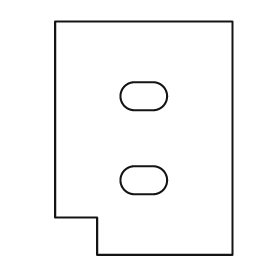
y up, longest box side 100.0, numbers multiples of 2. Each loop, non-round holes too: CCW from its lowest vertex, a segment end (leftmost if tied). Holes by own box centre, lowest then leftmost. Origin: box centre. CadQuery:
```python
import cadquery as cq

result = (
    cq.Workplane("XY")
    .moveTo(-20.0, -50.0)
    .lineTo(38.0, -50.0)
    .lineTo(38.0, 50.0)
    .lineTo(-38.0, 50.0)
    .lineTo(-38.0, -34.0)
    .lineTo(-20.0, -34.0)
    .close()
    .moveTo(-4.0, -24.0)
    .lineTo(4.0, -24.0)
    .threePointArc((10.0, -18.0), (4.0, -12.0))
    .lineTo(-4.0, -12.0)
    .threePointArc((-10.0, -18.0), (-4.0, -24.0))
    .close()
    .moveTo(-4.0, 12.0)
    .lineTo(4.0, 12.0)
    .threePointArc((10.0, 18.0), (4.0, 24.0))
    .lineTo(-4.0, 24.0)
    .threePointArc((-10.0, 18.0), (-4.0, 12.0))
    .close()
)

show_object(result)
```